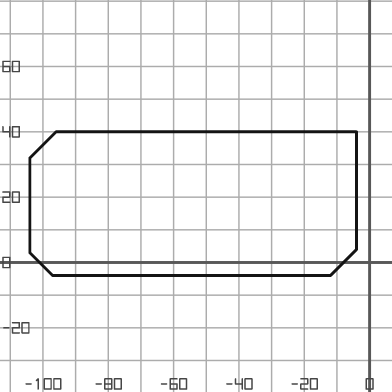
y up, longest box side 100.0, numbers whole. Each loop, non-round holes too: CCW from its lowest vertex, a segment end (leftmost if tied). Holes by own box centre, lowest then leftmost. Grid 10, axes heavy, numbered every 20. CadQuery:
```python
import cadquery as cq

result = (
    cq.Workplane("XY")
    .moveTo(-97.0, -4.0)
    .lineTo(-12.0, -4.0)
    .lineTo(-4.0, 4.0)
    .lineTo(-4.0, 40.0)
    .lineTo(-96.0, 40.0)
    .lineTo(-104.0, 32.0)
    .lineTo(-104.0, 3.0)
    .close()
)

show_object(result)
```